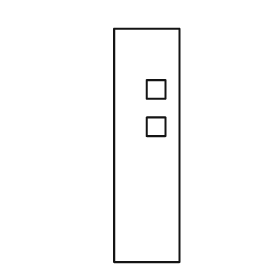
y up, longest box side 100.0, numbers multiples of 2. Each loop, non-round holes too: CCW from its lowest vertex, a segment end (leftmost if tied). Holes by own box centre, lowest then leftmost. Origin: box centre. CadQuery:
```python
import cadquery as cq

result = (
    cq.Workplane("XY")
    .moveTo(-14.0, -50.0)
    .lineTo(14.0, -50.0)
    .lineTo(14.0, 50.0)
    .lineTo(-14.0, 50.0)
    .close()
    .moveTo(0.0, 4.0)
    .lineTo(8.0, 4.0)
    .lineTo(8.0, 12.0)
    .lineTo(0.0, 12.0)
    .close()
    .moveTo(0.0, 20.0)
    .lineTo(8.0, 20.0)
    .lineTo(8.0, 28.0)
    .lineTo(0.0, 28.0)
    .close()
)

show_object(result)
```